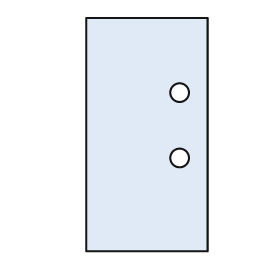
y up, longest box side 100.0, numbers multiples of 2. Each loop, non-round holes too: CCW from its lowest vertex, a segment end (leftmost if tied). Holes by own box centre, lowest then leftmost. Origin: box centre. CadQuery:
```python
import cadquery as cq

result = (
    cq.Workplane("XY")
    .moveTo(-26.0, -50.0)
    .lineTo(26.0, -50.0)
    .lineTo(26.0, 50.0)
    .lineTo(-26.0, 50.0)
    .close()
    .moveTo(14.0, -10.0)
    .circle(4.0)
    .moveTo(14.0, 18.0)
    .circle(4.0)
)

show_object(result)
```